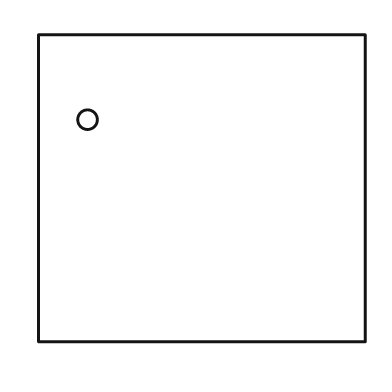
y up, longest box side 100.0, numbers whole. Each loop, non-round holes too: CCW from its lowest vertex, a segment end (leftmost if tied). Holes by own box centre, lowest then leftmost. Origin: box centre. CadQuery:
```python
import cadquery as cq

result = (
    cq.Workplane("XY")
    .moveTo(-50.0, -47.0)
    .lineTo(50.0, -47.0)
    .lineTo(50.0, 47.0)
    .lineTo(-50.0, 47.0)
    .close()
    .moveTo(-35.0, 21.0)
    .circle(3.0)
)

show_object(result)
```